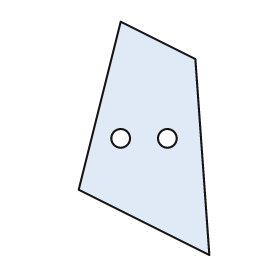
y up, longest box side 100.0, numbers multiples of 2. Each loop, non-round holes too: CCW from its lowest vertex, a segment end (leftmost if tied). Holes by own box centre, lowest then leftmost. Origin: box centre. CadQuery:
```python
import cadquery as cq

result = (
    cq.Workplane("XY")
    .moveTo(28.0, -50.0)
    .lineTo(22.0, 34.0)
    .lineTo(-10.0, 50.0)
    .lineTo(-28.0, -22.0)
    .close()
    .moveTo(-10.0, 0.0)
    .circle(4.0)
    .moveTo(10.0, 0.0)
    .circle(4.0)
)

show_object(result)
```